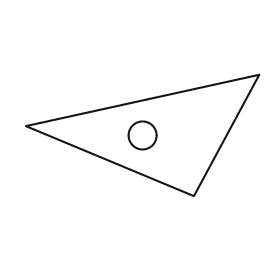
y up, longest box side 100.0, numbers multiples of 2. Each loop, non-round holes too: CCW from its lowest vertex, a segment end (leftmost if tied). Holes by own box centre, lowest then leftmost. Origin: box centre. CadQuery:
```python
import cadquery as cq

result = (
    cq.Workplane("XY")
    .moveTo(22.0, -26.0)
    .lineTo(50.0, 26.0)
    .lineTo(-50.0, 4.0)
    .close()
    .moveTo(0.0, 0.0)
    .circle(6.0)
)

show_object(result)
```